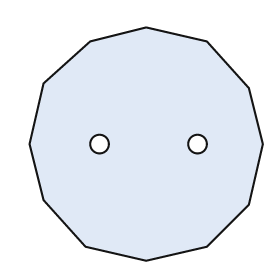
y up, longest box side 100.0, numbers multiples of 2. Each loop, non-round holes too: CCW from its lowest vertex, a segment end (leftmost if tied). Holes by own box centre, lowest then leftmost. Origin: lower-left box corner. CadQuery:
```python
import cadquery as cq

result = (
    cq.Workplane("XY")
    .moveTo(50.0, 0.0)
    .lineTo(76.0, 6.0)
    .lineTo(94.0, 24.0)
    .lineTo(100.0, 50.0)
    .lineTo(94.0, 74.0)
    .lineTo(76.0, 94.0)
    .lineTo(50.0, 100.0)
    .lineTo(26.0, 94.0)
    .lineTo(6.0, 76.0)
    .lineTo(0.0, 50.0)
    .lineTo(6.0, 26.0)
    .lineTo(24.0, 6.0)
    .close()
    .moveTo(30.0, 50.0)
    .circle(4.0)
    .moveTo(72.0, 50.0)
    .circle(4.0)
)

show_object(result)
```